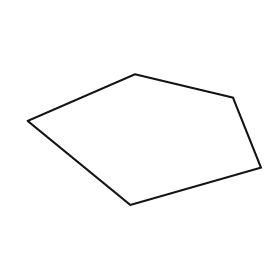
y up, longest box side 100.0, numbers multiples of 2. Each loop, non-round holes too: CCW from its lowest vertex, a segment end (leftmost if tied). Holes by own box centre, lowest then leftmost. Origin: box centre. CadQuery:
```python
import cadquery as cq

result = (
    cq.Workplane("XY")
    .moveTo(-6.0, -28.0)
    .lineTo(50.0, -12.0)
    .lineTo(38.0, 18.0)
    .lineTo(-4.0, 28.0)
    .lineTo(-50.0, 8.0)
    .close()
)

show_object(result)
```